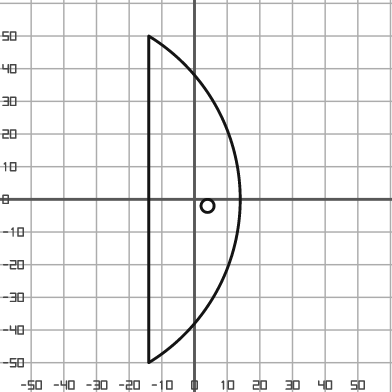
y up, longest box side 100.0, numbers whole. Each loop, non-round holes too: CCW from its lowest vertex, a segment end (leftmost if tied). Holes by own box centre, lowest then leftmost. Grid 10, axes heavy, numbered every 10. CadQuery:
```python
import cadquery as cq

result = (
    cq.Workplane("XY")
    .moveTo(-14.0, -50.0)
    .threePointArc((14.0, 0.0), (-14.0, 50.0))
    .close()
    .moveTo(4.0, -2.0)
    .circle(2.0)
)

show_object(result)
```